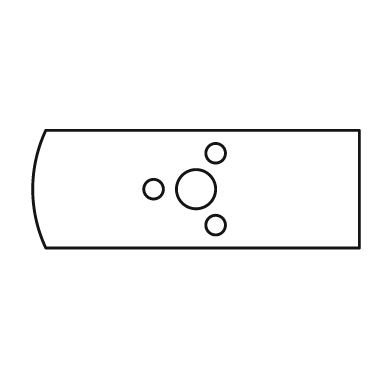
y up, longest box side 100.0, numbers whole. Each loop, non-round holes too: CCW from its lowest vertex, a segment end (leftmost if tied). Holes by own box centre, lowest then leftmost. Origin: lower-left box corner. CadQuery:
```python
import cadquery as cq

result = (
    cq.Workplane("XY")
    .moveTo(4.0, 0.0)
    .lineTo(100.0, 0.0)
    .lineTo(100.0, 36.0)
    .lineTo(4.0, 36.0)
    .threePointArc((0.0, 18.0), (4.0, 0.0))
    .close()
    .moveTo(56.0, 7.0)
    .circle(3.0)
    .moveTo(37.0, 18.0)
    .circle(3.0)
    .moveTo(50.0, 18.0)
    .circle(6.0)
    .moveTo(56.0, 29.0)
    .circle(3.0)
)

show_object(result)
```